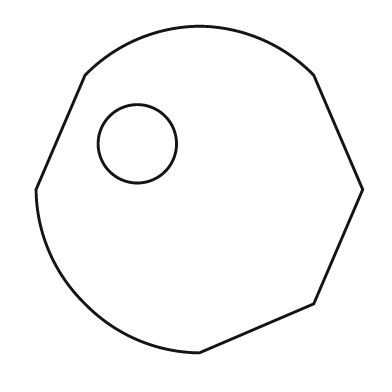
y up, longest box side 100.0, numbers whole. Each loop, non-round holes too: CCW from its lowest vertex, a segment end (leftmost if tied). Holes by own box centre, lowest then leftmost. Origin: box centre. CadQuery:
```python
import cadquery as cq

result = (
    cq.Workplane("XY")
    .moveTo(0.0, -50.0)
    .lineTo(35.0, -35.0)
    .lineTo(50.0, 0.0)
    .lineTo(35.0, 35.0)
    .threePointArc((19.0, 46.0), (0.0, 50.0))
    .threePointArc((-19.0, 46.0), (-35.0, 35.0))
    .lineTo(-50.0, 0.0)
    .threePointArc((-46.0, -19.0), (-35.0, -35.0))
    .threePointArc((-19.0, -46.0), (0.0, -50.0))
    .close()
    .moveTo(-19.0, 14.0)
    .circle(12.0)
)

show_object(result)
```